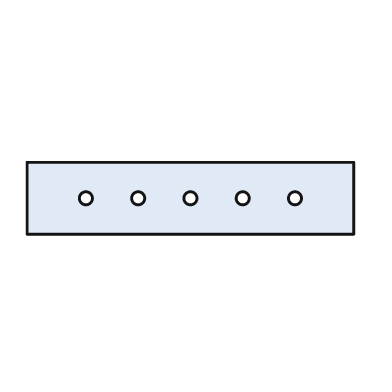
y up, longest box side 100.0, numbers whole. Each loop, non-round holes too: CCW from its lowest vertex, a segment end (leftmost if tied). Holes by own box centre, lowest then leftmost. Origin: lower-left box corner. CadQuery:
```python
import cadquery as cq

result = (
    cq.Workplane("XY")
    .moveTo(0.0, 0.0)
    .lineTo(100.0, 0.0)
    .lineTo(100.0, 22.0)
    .lineTo(0.0, 22.0)
    .close()
    .moveTo(18.0, 11.0)
    .circle(2.0)
    .moveTo(34.0, 11.0)
    .circle(2.0)
    .moveTo(50.0, 11.0)
    .circle(2.0)
    .moveTo(66.0, 11.0)
    .circle(2.0)
    .moveTo(82.0, 11.0)
    .circle(2.0)
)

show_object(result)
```